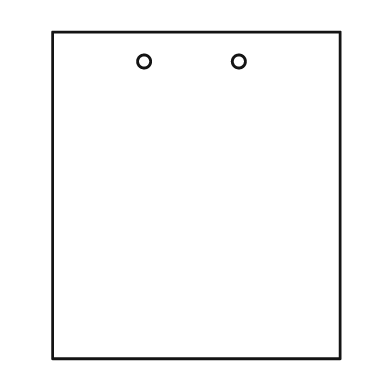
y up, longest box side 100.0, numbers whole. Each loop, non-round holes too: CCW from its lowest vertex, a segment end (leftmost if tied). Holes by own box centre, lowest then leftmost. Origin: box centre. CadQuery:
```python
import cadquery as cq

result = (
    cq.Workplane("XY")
    .moveTo(-44.0, -50.0)
    .lineTo(44.0, -50.0)
    .lineTo(44.0, 50.0)
    .lineTo(-44.0, 50.0)
    .close()
    .moveTo(-16.0, 41.0)
    .circle(2.0)
    .moveTo(13.0, 41.0)
    .circle(2.0)
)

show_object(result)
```